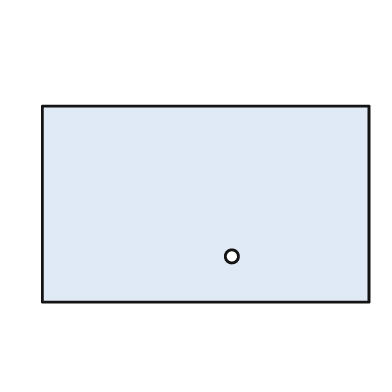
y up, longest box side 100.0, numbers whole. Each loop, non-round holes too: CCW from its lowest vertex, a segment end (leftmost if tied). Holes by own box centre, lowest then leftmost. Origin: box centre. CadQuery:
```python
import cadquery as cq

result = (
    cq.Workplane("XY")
    .moveTo(-50.0, -30.0)
    .lineTo(50.0, -30.0)
    .lineTo(50.0, 30.0)
    .lineTo(-50.0, 30.0)
    .close()
    .moveTo(8.0, -16.0)
    .circle(2.0)
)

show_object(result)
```